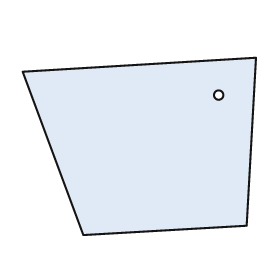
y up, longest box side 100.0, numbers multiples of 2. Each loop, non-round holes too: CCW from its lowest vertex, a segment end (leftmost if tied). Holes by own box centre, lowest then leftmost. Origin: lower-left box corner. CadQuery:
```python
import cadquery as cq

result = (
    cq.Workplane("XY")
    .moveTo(26.0, 0.0)
    .lineTo(96.0, 4.0)
    .lineTo(100.0, 76.0)
    .lineTo(0.0, 70.0)
    .close()
    .moveTo(84.0, 60.0)
    .circle(2.0)
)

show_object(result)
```